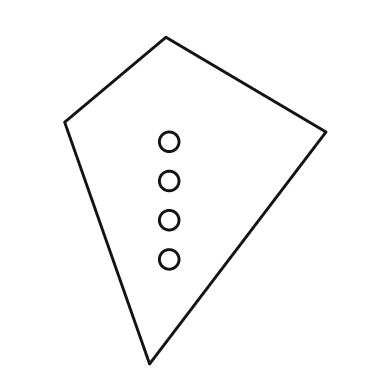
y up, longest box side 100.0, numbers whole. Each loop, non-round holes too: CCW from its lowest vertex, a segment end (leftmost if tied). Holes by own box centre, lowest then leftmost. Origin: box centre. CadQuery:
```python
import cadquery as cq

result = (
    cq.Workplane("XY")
    .moveTo(-14.0, -50.0)
    .lineTo(40.0, 21.0)
    .lineTo(-9.0, 50.0)
    .lineTo(-40.0, 24.0)
    .close()
    .moveTo(-8.0, -18.0)
    .circle(3.0)
    .moveTo(-8.0, -6.0)
    .circle(3.0)
    .moveTo(-8.0, 6.0)
    .circle(3.0)
    .moveTo(-8.0, 18.0)
    .circle(3.0)
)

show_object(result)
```